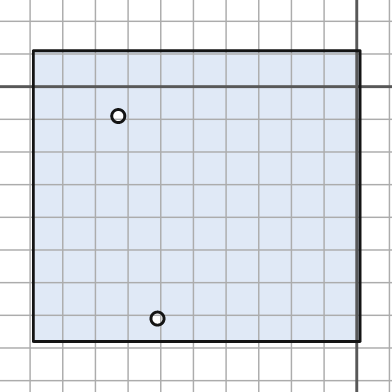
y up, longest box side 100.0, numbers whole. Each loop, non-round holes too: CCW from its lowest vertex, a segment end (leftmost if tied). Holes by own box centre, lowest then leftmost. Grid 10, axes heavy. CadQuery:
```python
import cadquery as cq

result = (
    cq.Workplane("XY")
    .moveTo(-99.0, -78.0)
    .lineTo(1.0, -78.0)
    .lineTo(1.0, 11.0)
    .lineTo(-99.0, 11.0)
    .close()
    .moveTo(-61.0, -71.0)
    .circle(2.0)
    .moveTo(-73.0, -9.0)
    .circle(2.0)
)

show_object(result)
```